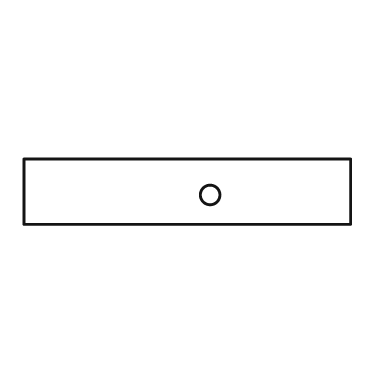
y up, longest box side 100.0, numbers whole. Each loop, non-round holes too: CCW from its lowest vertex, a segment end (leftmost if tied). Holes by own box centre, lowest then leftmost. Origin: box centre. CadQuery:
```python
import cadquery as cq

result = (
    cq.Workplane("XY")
    .moveTo(-50.0, -10.0)
    .lineTo(50.0, -10.0)
    .lineTo(50.0, 10.0)
    .lineTo(-50.0, 10.0)
    .close()
    .moveTo(7.0, -1.0)
    .circle(3.0)
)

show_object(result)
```